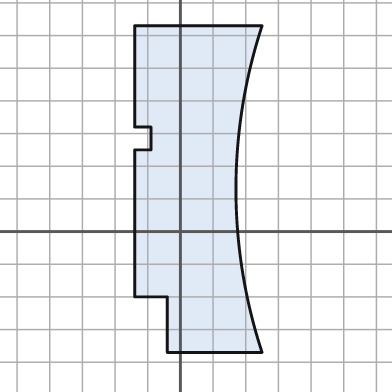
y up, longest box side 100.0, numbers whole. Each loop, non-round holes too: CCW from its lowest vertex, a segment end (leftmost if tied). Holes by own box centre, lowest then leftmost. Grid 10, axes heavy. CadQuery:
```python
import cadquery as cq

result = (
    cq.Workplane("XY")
    .moveTo(-4.0, -37.0)
    .lineTo(25.0, -37.0)
    .threePointArc((17.0, 13.0), (25.0, 63.0))
    .lineTo(-14.0, 63.0)
    .lineTo(-14.0, 32.0)
    .lineTo(-9.0, 32.0)
    .lineTo(-9.0, 25.0)
    .lineTo(-14.0, 25.0)
    .lineTo(-14.0, -20.0)
    .lineTo(-4.0, -20.0)
    .close()
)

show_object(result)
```